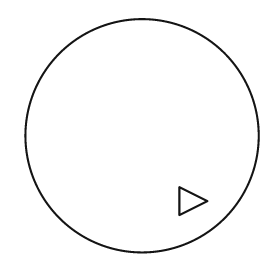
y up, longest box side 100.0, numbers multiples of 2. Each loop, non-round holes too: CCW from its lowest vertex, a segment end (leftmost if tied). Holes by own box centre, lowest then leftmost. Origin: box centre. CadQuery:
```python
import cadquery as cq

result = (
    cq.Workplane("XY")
    .moveTo(0.0, 0.0)
    .circle(50.0)
    .moveTo(16.0, -34.0)
    .lineTo(28.0, -28.0)
    .lineTo(16.0, -22.0)
    .close()
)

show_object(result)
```